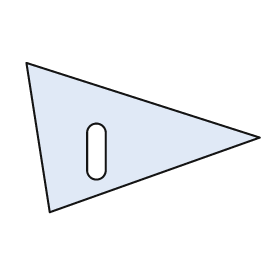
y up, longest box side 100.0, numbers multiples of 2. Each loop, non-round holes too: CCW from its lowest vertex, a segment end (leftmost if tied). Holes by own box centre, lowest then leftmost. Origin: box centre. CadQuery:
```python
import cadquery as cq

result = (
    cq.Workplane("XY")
    .moveTo(-40.0, -32.0)
    .lineTo(50.0, 0.0)
    .lineTo(-50.0, 32.0)
    .close()
    .moveTo(-24.0, -14.0)
    .threePointArc((-20.0, -18.0), (-16.0, -14.0))
    .lineTo(-16.0, 2.0)
    .threePointArc((-20.0, 6.0), (-24.0, 2.0))
    .close()
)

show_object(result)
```